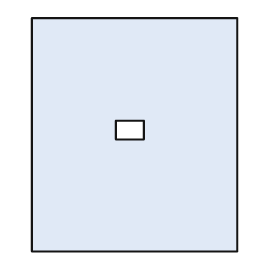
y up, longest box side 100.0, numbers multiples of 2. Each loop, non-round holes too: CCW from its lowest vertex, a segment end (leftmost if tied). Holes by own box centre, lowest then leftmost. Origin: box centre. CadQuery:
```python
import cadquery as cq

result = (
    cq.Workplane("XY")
    .moveTo(-44.0, -50.0)
    .lineTo(44.0, -50.0)
    .lineTo(44.0, 50.0)
    .lineTo(-44.0, 50.0)
    .close()
    .moveTo(-8.0, -2.0)
    .lineTo(4.0, -2.0)
    .lineTo(4.0, 6.0)
    .lineTo(-8.0, 6.0)
    .close()
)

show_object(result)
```